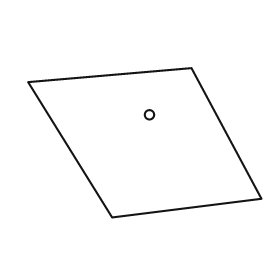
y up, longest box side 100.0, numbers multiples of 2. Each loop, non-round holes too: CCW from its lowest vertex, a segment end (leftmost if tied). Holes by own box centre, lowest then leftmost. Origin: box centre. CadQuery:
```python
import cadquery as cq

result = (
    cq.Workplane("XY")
    .moveTo(-14.0, -32.0)
    .lineTo(50.0, -24.0)
    .lineTo(20.0, 32.0)
    .lineTo(-50.0, 26.0)
    .close()
    .moveTo(2.0, 12.0)
    .circle(2.0)
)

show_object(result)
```